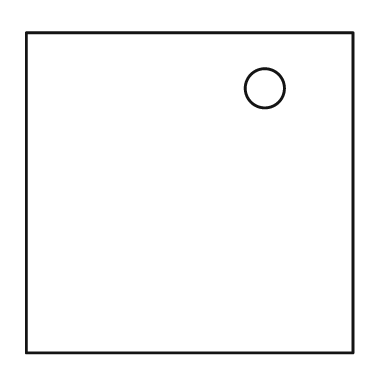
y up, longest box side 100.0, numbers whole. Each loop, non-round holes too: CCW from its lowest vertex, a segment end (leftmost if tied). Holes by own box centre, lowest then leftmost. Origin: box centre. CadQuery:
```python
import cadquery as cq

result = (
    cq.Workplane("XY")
    .moveTo(-50.0, -49.0)
    .lineTo(50.0, -49.0)
    .lineTo(50.0, 49.0)
    .lineTo(-50.0, 49.0)
    .close()
    .moveTo(23.0, 32.0)
    .circle(6.0)
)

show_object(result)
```